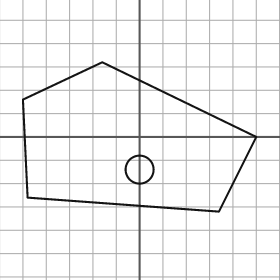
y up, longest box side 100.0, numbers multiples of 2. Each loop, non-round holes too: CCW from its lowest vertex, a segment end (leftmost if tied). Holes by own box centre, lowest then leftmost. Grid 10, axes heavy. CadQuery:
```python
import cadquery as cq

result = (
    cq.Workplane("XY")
    .moveTo(34.0, -32.0)
    .lineTo(50.0, 0.0)
    .lineTo(-16.0, 32.0)
    .lineTo(-50.0, 16.0)
    .lineTo(-48.0, -26.0)
    .close()
    .moveTo(0.0, -14.0)
    .circle(6.0)
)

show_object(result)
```